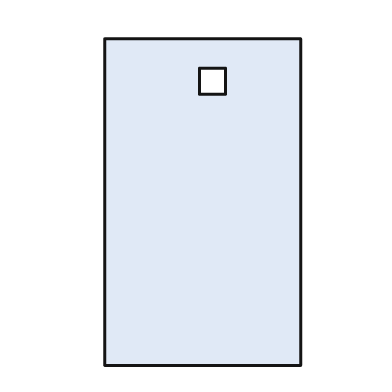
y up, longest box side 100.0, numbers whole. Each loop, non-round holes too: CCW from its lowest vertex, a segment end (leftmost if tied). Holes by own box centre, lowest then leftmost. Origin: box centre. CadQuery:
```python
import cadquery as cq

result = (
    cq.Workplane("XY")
    .moveTo(-30.0, -50.0)
    .lineTo(30.0, -50.0)
    .lineTo(30.0, 50.0)
    .lineTo(-30.0, 50.0)
    .close()
    .moveTo(-1.0, 33.0)
    .lineTo(7.0, 33.0)
    .lineTo(7.0, 41.0)
    .lineTo(-1.0, 41.0)
    .close()
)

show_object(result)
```